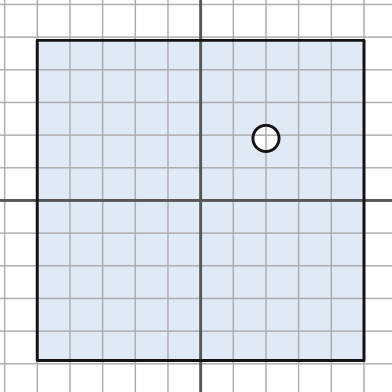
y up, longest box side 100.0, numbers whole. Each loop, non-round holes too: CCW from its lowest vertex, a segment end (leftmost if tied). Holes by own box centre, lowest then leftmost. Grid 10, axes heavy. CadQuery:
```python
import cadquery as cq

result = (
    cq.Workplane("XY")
    .moveTo(-50.0, -49.0)
    .lineTo(50.0, -49.0)
    .lineTo(50.0, 49.0)
    .lineTo(-50.0, 49.0)
    .close()
    .moveTo(20.0, 19.0)
    .circle(4.0)
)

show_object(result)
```